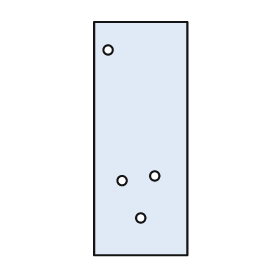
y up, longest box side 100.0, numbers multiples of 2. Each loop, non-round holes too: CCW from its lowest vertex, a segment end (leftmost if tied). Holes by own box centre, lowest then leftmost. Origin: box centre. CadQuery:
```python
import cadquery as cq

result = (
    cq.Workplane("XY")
    .moveTo(-20.0, -50.0)
    .lineTo(20.0, -50.0)
    .lineTo(20.0, 50.0)
    .lineTo(-20.0, 50.0)
    .close()
    .moveTo(0.0, -34.0)
    .circle(2.0)
    .moveTo(-8.0, -18.0)
    .circle(2.0)
    .moveTo(6.0, -16.0)
    .circle(2.0)
    .moveTo(-14.0, 38.0)
    .circle(2.0)
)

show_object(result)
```